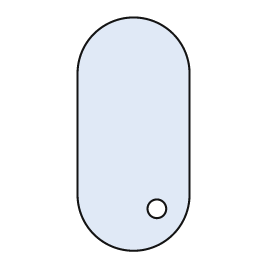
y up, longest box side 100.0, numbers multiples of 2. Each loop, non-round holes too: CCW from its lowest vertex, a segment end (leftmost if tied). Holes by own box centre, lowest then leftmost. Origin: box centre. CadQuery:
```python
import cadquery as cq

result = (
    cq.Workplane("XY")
    .moveTo(-24.0, -26.0)
    .threePointArc((0.0, -50.0), (24.0, -26.0))
    .lineTo(24.0, 26.0)
    .threePointArc((0.0, 50.0), (-24.0, 26.0))
    .close()
    .moveTo(10.0, -32.0)
    .circle(4.0)
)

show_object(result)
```